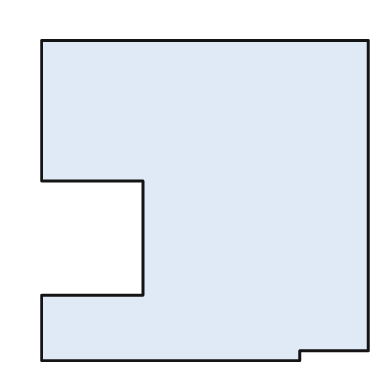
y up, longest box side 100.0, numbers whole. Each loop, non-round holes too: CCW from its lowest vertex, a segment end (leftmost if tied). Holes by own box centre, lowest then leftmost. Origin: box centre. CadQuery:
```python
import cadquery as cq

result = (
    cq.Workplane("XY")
    .moveTo(-50.0, -49.0)
    .lineTo(29.0, -49.0)
    .lineTo(29.0, -46.0)
    .lineTo(50.0, -46.0)
    .lineTo(50.0, 49.0)
    .lineTo(-50.0, 49.0)
    .lineTo(-50.0, 6.0)
    .lineTo(-19.0, 6.0)
    .lineTo(-19.0, -29.0)
    .lineTo(-50.0, -29.0)
    .close()
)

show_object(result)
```